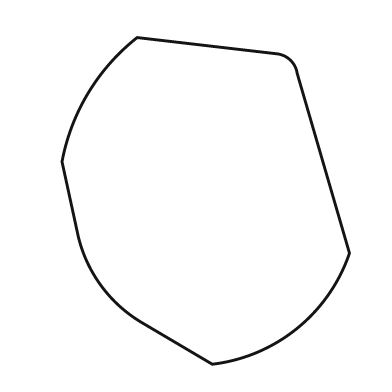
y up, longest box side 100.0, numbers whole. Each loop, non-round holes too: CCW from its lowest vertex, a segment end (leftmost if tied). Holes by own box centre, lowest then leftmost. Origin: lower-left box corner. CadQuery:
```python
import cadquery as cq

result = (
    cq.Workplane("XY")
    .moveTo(46.0, 0.0)
    .threePointArc((72.0, 11.0), (88.0, 34.0))
    .lineTo(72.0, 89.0)
    .threePointArc((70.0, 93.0), (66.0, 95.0))
    .lineTo(23.0, 100.0)
    .threePointArc((8.0, 83.0), (0.0, 62.0))
    .lineTo(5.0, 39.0)
    .threePointArc((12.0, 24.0), (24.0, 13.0))
    .close()
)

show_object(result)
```